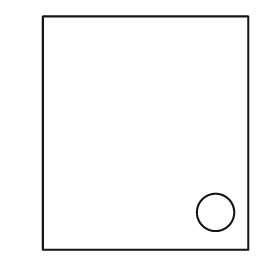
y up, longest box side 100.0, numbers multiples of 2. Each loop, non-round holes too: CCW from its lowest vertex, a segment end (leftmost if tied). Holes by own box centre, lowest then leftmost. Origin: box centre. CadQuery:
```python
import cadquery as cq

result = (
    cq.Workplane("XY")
    .moveTo(-44.0, -50.0)
    .lineTo(44.0, -50.0)
    .lineTo(44.0, 50.0)
    .lineTo(-44.0, 50.0)
    .close()
    .moveTo(30.0, -34.0)
    .circle(8.0)
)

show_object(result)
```